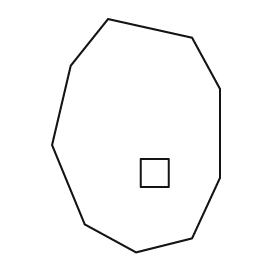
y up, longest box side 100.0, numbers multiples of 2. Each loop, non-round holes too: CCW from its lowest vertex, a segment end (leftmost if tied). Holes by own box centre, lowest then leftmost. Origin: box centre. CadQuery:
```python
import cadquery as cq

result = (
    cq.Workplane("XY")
    .moveTo(0.0, -50.0)
    .lineTo(24.0, -44.0)
    .lineTo(36.0, -18.0)
    .lineTo(36.0, 20.0)
    .lineTo(24.0, 42.0)
    .lineTo(-12.0, 50.0)
    .lineTo(-28.0, 30.0)
    .lineTo(-36.0, -4.0)
    .lineTo(-22.0, -38.0)
    .close()
    .moveTo(2.0, -22.0)
    .lineTo(14.0, -22.0)
    .lineTo(14.0, -10.0)
    .lineTo(2.0, -10.0)
    .close()
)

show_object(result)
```